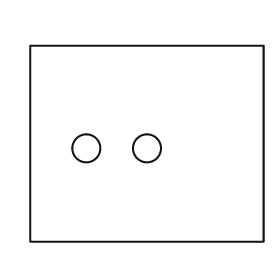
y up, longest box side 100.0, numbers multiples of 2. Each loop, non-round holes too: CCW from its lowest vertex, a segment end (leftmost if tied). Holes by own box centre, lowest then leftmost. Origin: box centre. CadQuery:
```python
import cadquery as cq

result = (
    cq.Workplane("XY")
    .moveTo(-50.0, -42.0)
    .lineTo(50.0, -42.0)
    .lineTo(50.0, 42.0)
    .lineTo(-50.0, 42.0)
    .close()
    .moveTo(-26.0, -2.0)
    .circle(6.0)
    .moveTo(0.0, -2.0)
    .circle(6.0)
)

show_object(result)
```